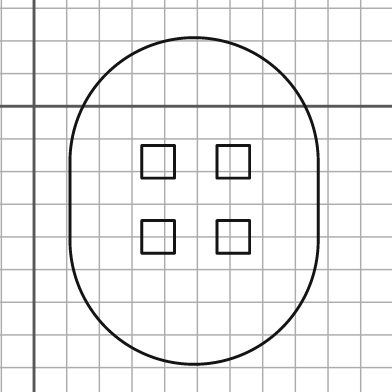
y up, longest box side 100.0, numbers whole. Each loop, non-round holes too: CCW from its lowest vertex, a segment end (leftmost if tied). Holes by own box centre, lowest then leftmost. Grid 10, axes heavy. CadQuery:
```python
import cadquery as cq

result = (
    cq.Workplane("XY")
    .moveTo(11.0, -41.0)
    .threePointArc((49.0, -79.0), (87.0, -41.0))
    .lineTo(87.0, -17.0)
    .threePointArc((49.0, 21.0), (11.0, -17.0))
    .close()
    .moveTo(33.0, -45.0)
    .lineTo(43.0, -45.0)
    .lineTo(43.0, -35.0)
    .lineTo(33.0, -35.0)
    .close()
    .moveTo(56.0, -45.0)
    .lineTo(66.0, -45.0)
    .lineTo(66.0, -35.0)
    .lineTo(56.0, -35.0)
    .close()
    .moveTo(33.0, -22.0)
    .lineTo(43.0, -22.0)
    .lineTo(43.0, -12.0)
    .lineTo(33.0, -12.0)
    .close()
    .moveTo(56.0, -22.0)
    .lineTo(66.0, -22.0)
    .lineTo(66.0, -12.0)
    .lineTo(56.0, -12.0)
    .close()
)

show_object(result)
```